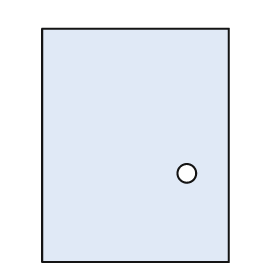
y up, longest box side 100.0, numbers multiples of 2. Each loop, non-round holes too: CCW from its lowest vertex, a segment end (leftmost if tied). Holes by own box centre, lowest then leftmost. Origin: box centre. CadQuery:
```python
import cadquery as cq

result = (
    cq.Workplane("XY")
    .moveTo(-40.0, -50.0)
    .lineTo(40.0, -50.0)
    .lineTo(40.0, 50.0)
    .lineTo(-40.0, 50.0)
    .close()
    .moveTo(22.0, -12.0)
    .circle(4.0)
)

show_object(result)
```